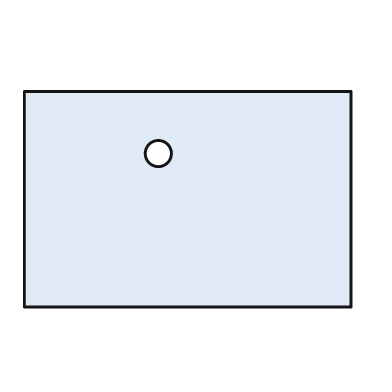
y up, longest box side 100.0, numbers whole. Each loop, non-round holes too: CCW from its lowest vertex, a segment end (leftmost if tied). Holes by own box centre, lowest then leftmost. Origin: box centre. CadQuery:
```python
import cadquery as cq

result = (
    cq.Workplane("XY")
    .moveTo(-50.0, -33.0)
    .lineTo(50.0, -33.0)
    .lineTo(50.0, 33.0)
    .lineTo(-50.0, 33.0)
    .close()
    .moveTo(-9.0, 14.0)
    .circle(4.0)
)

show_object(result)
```